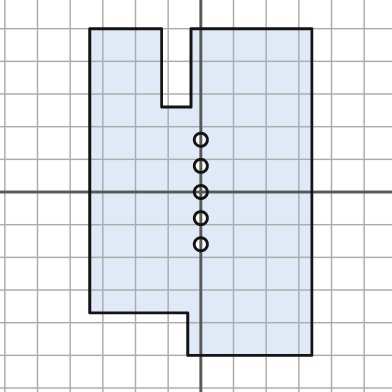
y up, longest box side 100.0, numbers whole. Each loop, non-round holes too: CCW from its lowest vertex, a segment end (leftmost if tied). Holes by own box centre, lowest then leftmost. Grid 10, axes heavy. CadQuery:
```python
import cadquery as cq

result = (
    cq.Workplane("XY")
    .moveTo(-4.0, -50.0)
    .lineTo(34.0, -50.0)
    .lineTo(34.0, 50.0)
    .lineTo(-3.0, 50.0)
    .lineTo(-3.0, 26.0)
    .lineTo(-12.0, 26.0)
    .lineTo(-12.0, 50.0)
    .lineTo(-34.0, 50.0)
    .lineTo(-34.0, -37.0)
    .lineTo(-4.0, -37.0)
    .close()
    .moveTo(0.0, -16.0)
    .circle(2.0)
    .moveTo(0.0, -8.0)
    .circle(2.0)
    .moveTo(0.0, 0.0)
    .circle(2.0)
    .moveTo(0.0, 8.0)
    .circle(2.0)
    .moveTo(0.0, 16.0)
    .circle(2.0)
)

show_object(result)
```